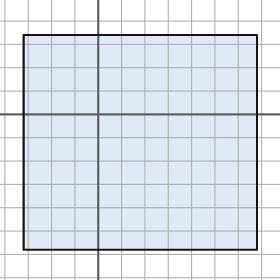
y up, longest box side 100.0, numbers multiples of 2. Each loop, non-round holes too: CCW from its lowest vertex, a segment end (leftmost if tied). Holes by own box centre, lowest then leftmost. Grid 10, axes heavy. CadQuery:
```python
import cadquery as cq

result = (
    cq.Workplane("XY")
    .moveTo(-32.0, -58.0)
    .lineTo(68.0, -58.0)
    .lineTo(68.0, 34.0)
    .lineTo(-32.0, 34.0)
    .close()
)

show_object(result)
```